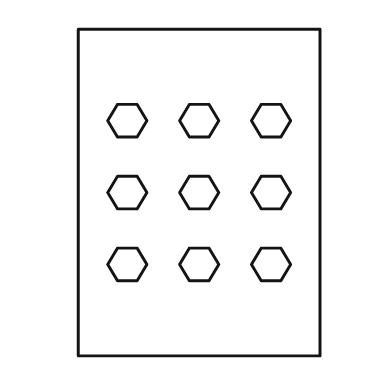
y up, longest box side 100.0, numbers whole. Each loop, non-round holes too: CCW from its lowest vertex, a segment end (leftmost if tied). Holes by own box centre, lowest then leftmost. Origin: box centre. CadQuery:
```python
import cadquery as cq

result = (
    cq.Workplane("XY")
    .moveTo(-37.0, -50.0)
    .lineTo(37.0, -50.0)
    .lineTo(37.0, 50.0)
    .lineTo(-37.0, 50.0)
    .close()
    .moveTo(-25.0, -27.0)
    .lineTo(-19.0, -27.0)
    .lineTo(-16.0, -22.0)
    .lineTo(-19.0, -17.0)
    .lineTo(-25.0, -17.0)
    .lineTo(-28.0, -22.0)
    .close()
    .moveTo(-3.0, -27.0)
    .lineTo(3.0, -27.0)
    .lineTo(6.0, -22.0)
    .lineTo(3.0, -17.0)
    .lineTo(-3.0, -17.0)
    .lineTo(-6.0, -22.0)
    .close()
    .moveTo(19.0, -27.0)
    .lineTo(25.0, -27.0)
    .lineTo(28.0, -22.0)
    .lineTo(25.0, -17.0)
    .lineTo(19.0, -17.0)
    .lineTo(16.0, -22.0)
    .close()
    .moveTo(-25.0, -5.0)
    .lineTo(-19.0, -5.0)
    .lineTo(-16.0, 0.0)
    .lineTo(-19.0, 5.0)
    .lineTo(-25.0, 5.0)
    .lineTo(-28.0, 0.0)
    .close()
    .moveTo(-3.0, -5.0)
    .lineTo(3.0, -5.0)
    .lineTo(6.0, 0.0)
    .lineTo(3.0, 5.0)
    .lineTo(-3.0, 5.0)
    .lineTo(-6.0, 0.0)
    .close()
    .moveTo(19.0, -5.0)
    .lineTo(25.0, -5.0)
    .lineTo(28.0, 0.0)
    .lineTo(25.0, 5.0)
    .lineTo(19.0, 5.0)
    .lineTo(16.0, 0.0)
    .close()
    .moveTo(-25.0, 17.0)
    .lineTo(-19.0, 17.0)
    .lineTo(-16.0, 22.0)
    .lineTo(-19.0, 27.0)
    .lineTo(-25.0, 27.0)
    .lineTo(-28.0, 22.0)
    .close()
    .moveTo(-3.0, 17.0)
    .lineTo(3.0, 17.0)
    .lineTo(6.0, 22.0)
    .lineTo(3.0, 27.0)
    .lineTo(-3.0, 27.0)
    .lineTo(-6.0, 22.0)
    .close()
    .moveTo(19.0, 17.0)
    .lineTo(25.0, 17.0)
    .lineTo(28.0, 22.0)
    .lineTo(25.0, 27.0)
    .lineTo(19.0, 27.0)
    .lineTo(16.0, 22.0)
    .close()
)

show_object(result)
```